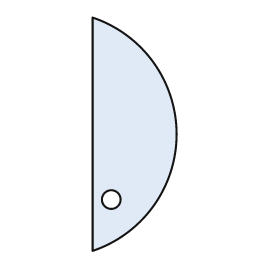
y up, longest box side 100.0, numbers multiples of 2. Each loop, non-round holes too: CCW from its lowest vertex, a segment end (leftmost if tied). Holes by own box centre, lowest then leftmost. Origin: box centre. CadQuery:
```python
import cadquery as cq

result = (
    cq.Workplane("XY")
    .moveTo(-18.0, -50.0)
    .threePointArc((18.0, 0.0), (-18.0, 50.0))
    .close()
    .moveTo(-10.0, -28.0)
    .circle(4.0)
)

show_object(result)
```